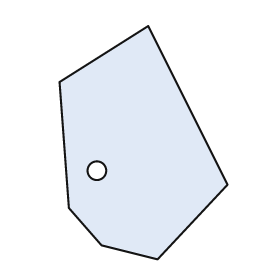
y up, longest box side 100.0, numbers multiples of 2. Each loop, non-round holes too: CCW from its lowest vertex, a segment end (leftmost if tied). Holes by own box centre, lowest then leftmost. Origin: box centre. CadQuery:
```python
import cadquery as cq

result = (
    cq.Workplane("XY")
    .moveTo(6.0, -50.0)
    .lineTo(36.0, -18.0)
    .lineTo(2.0, 50.0)
    .lineTo(-36.0, 26.0)
    .lineTo(-32.0, -28.0)
    .lineTo(-18.0, -44.0)
    .close()
    .moveTo(-20.0, -12.0)
    .circle(4.0)
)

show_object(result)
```